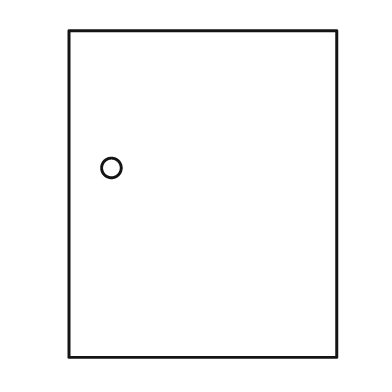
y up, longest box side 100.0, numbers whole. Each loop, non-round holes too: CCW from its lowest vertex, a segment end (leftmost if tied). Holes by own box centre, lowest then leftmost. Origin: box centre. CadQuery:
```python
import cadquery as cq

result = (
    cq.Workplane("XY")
    .moveTo(-41.0, -50.0)
    .lineTo(41.0, -50.0)
    .lineTo(41.0, 50.0)
    .lineTo(-41.0, 50.0)
    .close()
    .moveTo(-28.0, 8.0)
    .circle(3.0)
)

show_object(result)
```